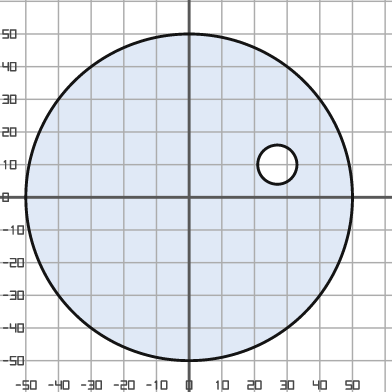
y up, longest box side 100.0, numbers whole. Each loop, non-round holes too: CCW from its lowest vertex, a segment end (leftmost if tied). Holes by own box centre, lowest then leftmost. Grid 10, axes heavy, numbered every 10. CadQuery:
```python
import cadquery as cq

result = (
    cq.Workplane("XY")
    .moveTo(0.0, 0.0)
    .circle(50.0)
    .moveTo(27.0, 10.0)
    .circle(6.0)
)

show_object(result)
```